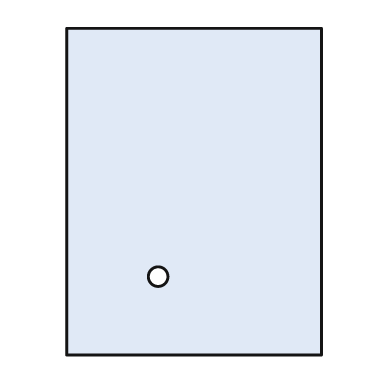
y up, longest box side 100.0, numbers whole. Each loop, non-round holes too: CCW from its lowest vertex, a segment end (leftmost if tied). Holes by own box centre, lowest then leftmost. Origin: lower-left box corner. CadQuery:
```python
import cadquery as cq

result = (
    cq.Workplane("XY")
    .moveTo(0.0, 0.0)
    .lineTo(78.0, 0.0)
    .lineTo(78.0, 100.0)
    .lineTo(0.0, 100.0)
    .close()
    .moveTo(28.0, 24.0)
    .circle(3.0)
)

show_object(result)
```